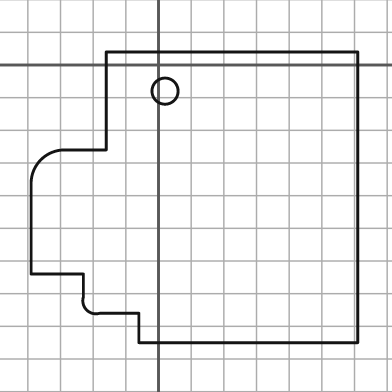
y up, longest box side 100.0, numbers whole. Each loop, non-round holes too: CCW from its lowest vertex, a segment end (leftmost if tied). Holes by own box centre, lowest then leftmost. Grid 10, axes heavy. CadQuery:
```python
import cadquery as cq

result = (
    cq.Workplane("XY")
    .moveTo(-6.0, -85.0)
    .lineTo(61.0, -85.0)
    .lineTo(61.0, 4.0)
    .lineTo(-16.0, 4.0)
    .lineTo(-16.0, -26.0)
    .lineTo(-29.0, -26.0)
    .threePointArc((-36.0, -29.0), (-39.0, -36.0))
    .lineTo(-39.0, -64.0)
    .lineTo(-23.0, -64.0)
    .lineTo(-23.0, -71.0)
    .threePointArc((-22.0, -75.0), (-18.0, -76.0))
    .lineTo(-6.0, -76.0)
    .close()
    .moveTo(2.0, -8.0)
    .circle(4.0)
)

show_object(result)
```